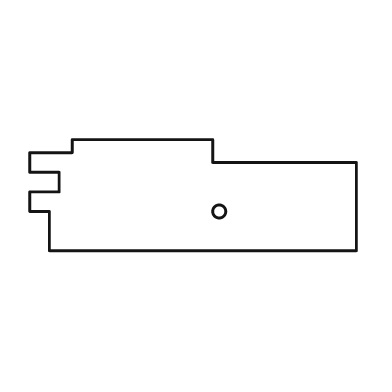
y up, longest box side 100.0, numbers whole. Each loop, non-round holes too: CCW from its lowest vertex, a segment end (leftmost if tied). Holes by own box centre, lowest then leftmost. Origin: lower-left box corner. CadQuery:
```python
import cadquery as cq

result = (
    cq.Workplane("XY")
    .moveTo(6.0, 0.0)
    .lineTo(100.0, 0.0)
    .lineTo(100.0, 27.0)
    .lineTo(56.0, 27.0)
    .lineTo(56.0, 34.0)
    .lineTo(13.0, 34.0)
    .lineTo(13.0, 30.0)
    .lineTo(0.0, 30.0)
    .lineTo(0.0, 24.0)
    .lineTo(9.0, 24.0)
    .lineTo(9.0, 18.0)
    .lineTo(0.0, 18.0)
    .lineTo(0.0, 12.0)
    .lineTo(6.0, 12.0)
    .close()
    .moveTo(58.0, 12.0)
    .circle(2.0)
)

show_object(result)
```